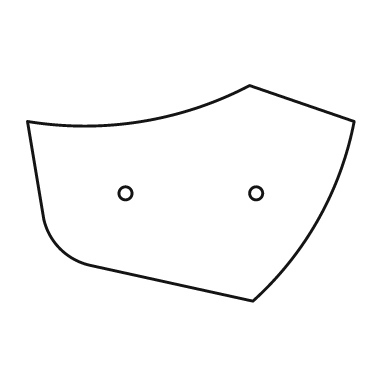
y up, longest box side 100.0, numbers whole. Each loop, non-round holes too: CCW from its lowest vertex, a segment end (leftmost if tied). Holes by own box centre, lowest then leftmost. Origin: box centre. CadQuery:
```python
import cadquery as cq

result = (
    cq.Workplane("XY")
    .moveTo(19.0, -33.0)
    .threePointArc((39.0, -8.0), (50.0, 22.0))
    .lineTo(18.0, 33.0)
    .threePointArc((-15.0, 22.0), (-50.0, 22.0))
    .lineTo(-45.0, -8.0)
    .threePointArc((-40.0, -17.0), (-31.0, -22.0))
    .close()
    .moveTo(-20.0, 0.0)
    .circle(2.0)
    .moveTo(20.0, 0.0)
    .circle(2.0)
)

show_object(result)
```